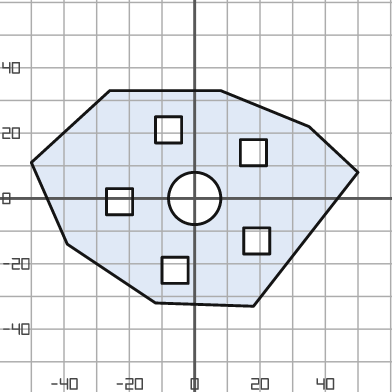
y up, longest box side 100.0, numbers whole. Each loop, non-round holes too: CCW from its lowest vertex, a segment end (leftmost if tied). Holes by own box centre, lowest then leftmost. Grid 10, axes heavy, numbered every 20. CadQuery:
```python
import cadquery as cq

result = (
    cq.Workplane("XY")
    .moveTo(18.0, -33.0)
    .lineTo(50.0, 8.0)
    .lineTo(35.0, 22.0)
    .lineTo(8.0, 33.0)
    .lineTo(-26.0, 33.0)
    .lineTo(-50.0, 11.0)
    .lineTo(-39.0, -14.0)
    .lineTo(-12.0, -32.0)
    .close()
    .moveTo(-10.0, -26.0)
    .lineTo(-2.0, -26.0)
    .lineTo(-2.0, -18.0)
    .lineTo(-10.0, -18.0)
    .close()
    .moveTo(15.0, -17.0)
    .lineTo(23.0, -17.0)
    .lineTo(23.0, -9.0)
    .lineTo(15.0, -9.0)
    .close()
    .moveTo(-27.0, -5.0)
    .lineTo(-19.0, -5.0)
    .lineTo(-19.0, 3.0)
    .lineTo(-27.0, 3.0)
    .close()
    .moveTo(0.0, 0.0)
    .circle(8.0)
    .moveTo(14.0, 10.0)
    .lineTo(22.0, 10.0)
    .lineTo(22.0, 18.0)
    .lineTo(14.0, 18.0)
    .close()
    .moveTo(-12.0, 17.0)
    .lineTo(-4.0, 17.0)
    .lineTo(-4.0, 25.0)
    .lineTo(-12.0, 25.0)
    .close()
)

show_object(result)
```